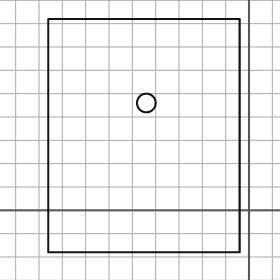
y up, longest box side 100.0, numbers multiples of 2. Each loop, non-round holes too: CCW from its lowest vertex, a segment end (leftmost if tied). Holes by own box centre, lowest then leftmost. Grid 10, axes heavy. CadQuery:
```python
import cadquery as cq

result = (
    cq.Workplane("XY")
    .moveTo(-86.0, -18.0)
    .lineTo(-4.0, -18.0)
    .lineTo(-4.0, 82.0)
    .lineTo(-86.0, 82.0)
    .close()
    .moveTo(-44.0, 46.0)
    .circle(4.0)
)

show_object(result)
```